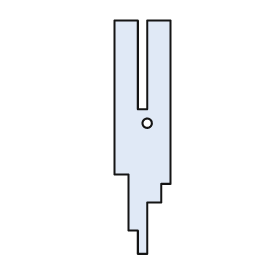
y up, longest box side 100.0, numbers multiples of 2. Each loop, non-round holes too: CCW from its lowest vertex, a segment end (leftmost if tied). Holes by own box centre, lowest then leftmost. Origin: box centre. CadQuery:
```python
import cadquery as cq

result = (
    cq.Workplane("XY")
    .moveTo(-2.0, -50.0)
    .lineTo(2.0, -50.0)
    .lineTo(2.0, -28.0)
    .lineTo(8.0, -28.0)
    .lineTo(8.0, -20.0)
    .lineTo(12.0, -20.0)
    .lineTo(12.0, 50.0)
    .lineTo(2.0, 50.0)
    .lineTo(2.0, 12.0)
    .lineTo(-2.0, 12.0)
    .lineTo(-2.0, 50.0)
    .lineTo(-12.0, 50.0)
    .lineTo(-12.0, -16.0)
    .lineTo(-6.0, -16.0)
    .lineTo(-6.0, -40.0)
    .lineTo(-2.0, -40.0)
    .close()
    .moveTo(2.0, 6.0)
    .circle(2.0)
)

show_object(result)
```